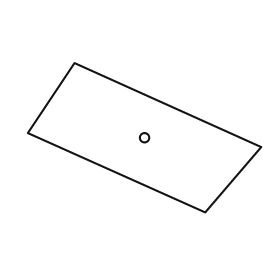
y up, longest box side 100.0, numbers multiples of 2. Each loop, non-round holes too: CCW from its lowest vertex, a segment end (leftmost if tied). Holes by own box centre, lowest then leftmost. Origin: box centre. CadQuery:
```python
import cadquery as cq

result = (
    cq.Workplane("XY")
    .moveTo(26.0, -32.0)
    .lineTo(50.0, -4.0)
    .lineTo(-30.0, 32.0)
    .lineTo(-50.0, 2.0)
    .close()
    .moveTo(0.0, 0.0)
    .circle(2.0)
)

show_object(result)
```